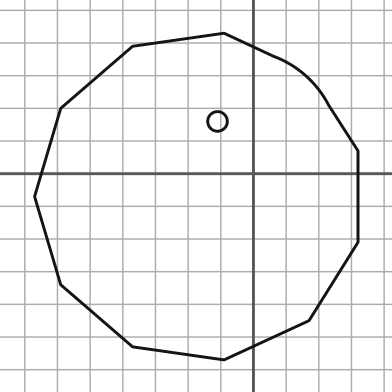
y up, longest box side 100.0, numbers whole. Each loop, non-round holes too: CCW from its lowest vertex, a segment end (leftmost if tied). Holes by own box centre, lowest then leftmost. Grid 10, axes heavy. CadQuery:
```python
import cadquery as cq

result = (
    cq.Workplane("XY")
    .moveTo(-9.0, -57.0)
    .lineTo(17.0, -45.0)
    .lineTo(32.0, -21.0)
    .lineTo(32.0, 7.0)
    .lineTo(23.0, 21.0)
    .threePointArc((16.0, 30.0), (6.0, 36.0))
    .lineTo(-9.0, 43.0)
    .lineTo(-37.0, 39.0)
    .lineTo(-59.0, 20.0)
    .lineTo(-67.0, -7.0)
    .lineTo(-59.0, -34.0)
    .lineTo(-37.0, -53.0)
    .close()
    .moveTo(-11.0, 16.0)
    .circle(3.0)
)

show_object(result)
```